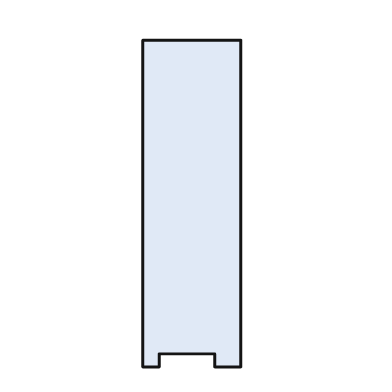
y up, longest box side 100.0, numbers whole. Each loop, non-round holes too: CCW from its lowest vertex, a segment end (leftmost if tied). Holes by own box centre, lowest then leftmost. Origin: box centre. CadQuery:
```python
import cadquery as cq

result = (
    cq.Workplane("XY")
    .moveTo(-15.0, -50.0)
    .lineTo(-10.0, -50.0)
    .lineTo(-10.0, -46.0)
    .lineTo(7.0, -46.0)
    .lineTo(7.0, -50.0)
    .lineTo(15.0, -50.0)
    .lineTo(15.0, 50.0)
    .lineTo(-15.0, 50.0)
    .close()
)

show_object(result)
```